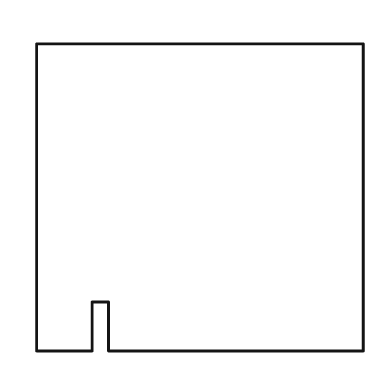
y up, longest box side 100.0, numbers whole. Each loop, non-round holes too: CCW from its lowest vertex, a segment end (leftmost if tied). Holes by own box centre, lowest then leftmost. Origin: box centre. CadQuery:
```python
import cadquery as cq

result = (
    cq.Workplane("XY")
    .moveTo(-50.0, -47.0)
    .lineTo(-33.0, -47.0)
    .lineTo(-33.0, -32.0)
    .lineTo(-28.0, -32.0)
    .lineTo(-28.0, -47.0)
    .lineTo(50.0, -47.0)
    .lineTo(50.0, 47.0)
    .lineTo(-50.0, 47.0)
    .close()
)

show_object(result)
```